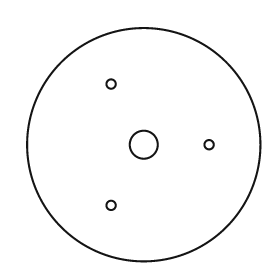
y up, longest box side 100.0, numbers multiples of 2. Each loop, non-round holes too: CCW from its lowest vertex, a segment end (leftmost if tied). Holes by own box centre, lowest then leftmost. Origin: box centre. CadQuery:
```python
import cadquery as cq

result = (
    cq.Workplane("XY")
    .moveTo(0.0, 0.0)
    .circle(50.0)
    .moveTo(-14.0, -26.0)
    .circle(2.0)
    .moveTo(0.0, 0.0)
    .circle(6.0)
    .moveTo(28.0, 0.0)
    .circle(2.0)
    .moveTo(-14.0, 26.0)
    .circle(2.0)
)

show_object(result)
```